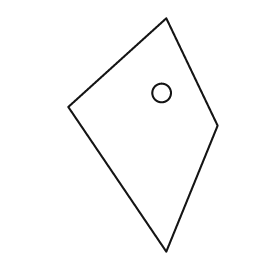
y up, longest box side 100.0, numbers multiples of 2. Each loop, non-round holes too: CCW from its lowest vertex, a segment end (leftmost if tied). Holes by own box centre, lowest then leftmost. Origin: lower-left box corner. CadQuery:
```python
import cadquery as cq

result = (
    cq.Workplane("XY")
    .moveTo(42.0, 0.0)
    .lineTo(64.0, 54.0)
    .lineTo(42.0, 100.0)
    .lineTo(0.0, 62.0)
    .close()
    .moveTo(40.0, 68.0)
    .circle(4.0)
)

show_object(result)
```